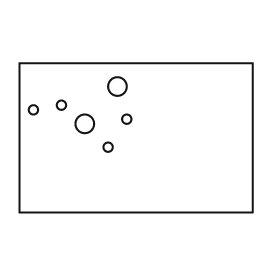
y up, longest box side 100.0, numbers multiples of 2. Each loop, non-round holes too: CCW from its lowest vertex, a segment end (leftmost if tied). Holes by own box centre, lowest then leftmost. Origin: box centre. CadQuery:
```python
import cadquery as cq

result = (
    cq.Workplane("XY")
    .moveTo(-50.0, -32.0)
    .lineTo(50.0, -32.0)
    .lineTo(50.0, 32.0)
    .lineTo(-50.0, 32.0)
    .close()
    .moveTo(-12.0, -4.0)
    .circle(2.0)
    .moveTo(-22.0, 6.0)
    .circle(4.0)
    .moveTo(-4.0, 8.0)
    .circle(2.0)
    .moveTo(-44.0, 12.0)
    .circle(2.0)
    .moveTo(-32.0, 14.0)
    .circle(2.0)
    .moveTo(-8.0, 22.0)
    .circle(4.0)
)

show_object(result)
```